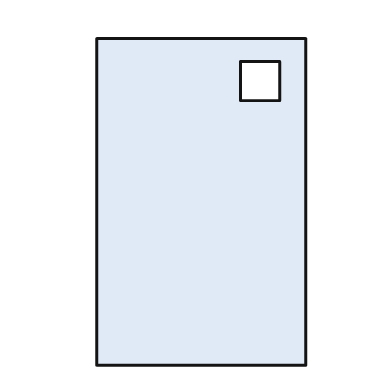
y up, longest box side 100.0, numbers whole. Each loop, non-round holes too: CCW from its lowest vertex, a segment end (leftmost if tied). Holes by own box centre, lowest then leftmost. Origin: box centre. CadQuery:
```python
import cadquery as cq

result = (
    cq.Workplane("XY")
    .moveTo(-32.0, -50.0)
    .lineTo(32.0, -50.0)
    .lineTo(32.0, 50.0)
    .lineTo(-32.0, 50.0)
    .close()
    .moveTo(12.0, 31.0)
    .lineTo(24.0, 31.0)
    .lineTo(24.0, 43.0)
    .lineTo(12.0, 43.0)
    .close()
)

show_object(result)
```